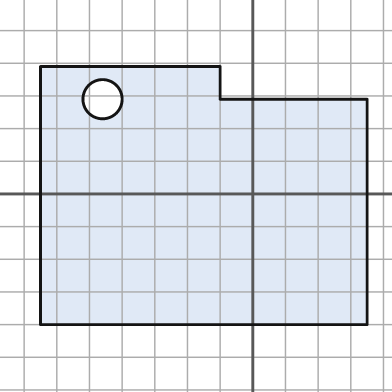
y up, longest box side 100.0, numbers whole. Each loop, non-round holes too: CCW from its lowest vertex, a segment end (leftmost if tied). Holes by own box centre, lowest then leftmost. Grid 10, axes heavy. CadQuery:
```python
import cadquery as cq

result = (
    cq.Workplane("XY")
    .moveTo(-65.0, -40.0)
    .lineTo(35.0, -40.0)
    .lineTo(35.0, 29.0)
    .lineTo(-10.0, 29.0)
    .lineTo(-10.0, 39.0)
    .lineTo(-65.0, 39.0)
    .close()
    .moveTo(-46.0, 29.0)
    .circle(6.0)
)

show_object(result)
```